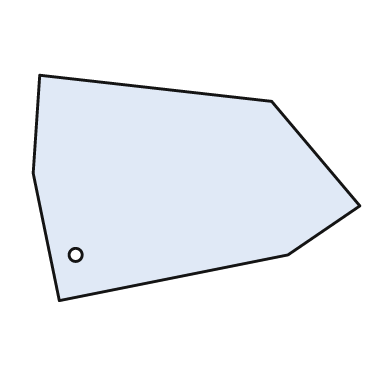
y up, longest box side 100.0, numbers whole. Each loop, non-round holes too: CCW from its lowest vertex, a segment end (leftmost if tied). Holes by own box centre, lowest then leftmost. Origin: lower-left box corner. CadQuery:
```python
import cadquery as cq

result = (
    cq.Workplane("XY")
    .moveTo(8.0, 0.0)
    .lineTo(78.0, 14.0)
    .lineTo(100.0, 29.0)
    .lineTo(73.0, 61.0)
    .lineTo(2.0, 69.0)
    .lineTo(0.0, 39.0)
    .close()
    .moveTo(13.0, 14.0)
    .circle(2.0)
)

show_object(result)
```